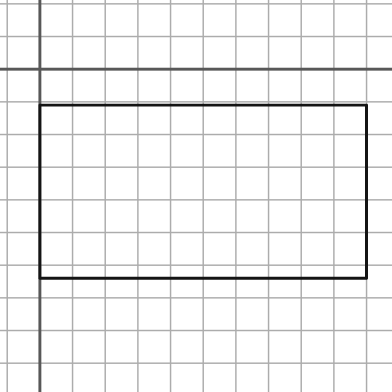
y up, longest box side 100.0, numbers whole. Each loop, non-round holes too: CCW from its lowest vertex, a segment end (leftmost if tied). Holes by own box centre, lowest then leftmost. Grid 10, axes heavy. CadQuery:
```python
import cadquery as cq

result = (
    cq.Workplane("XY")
    .moveTo(0.0, -64.0)
    .lineTo(100.0, -64.0)
    .lineTo(100.0, -11.0)
    .lineTo(0.0, -11.0)
    .close()
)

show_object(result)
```